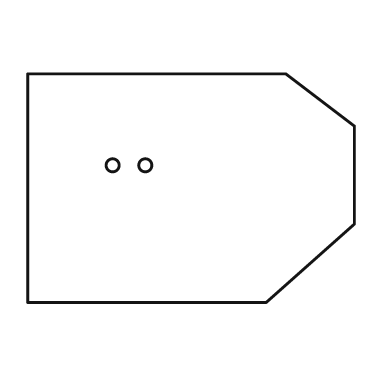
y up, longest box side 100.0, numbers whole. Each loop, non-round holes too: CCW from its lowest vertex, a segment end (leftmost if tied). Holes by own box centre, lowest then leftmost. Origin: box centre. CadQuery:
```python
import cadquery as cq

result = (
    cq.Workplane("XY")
    .moveTo(-50.0, -35.0)
    .lineTo(23.0, -35.0)
    .lineTo(50.0, -11.0)
    .lineTo(50.0, 19.0)
    .lineTo(29.0, 35.0)
    .lineTo(-50.0, 35.0)
    .close()
    .moveTo(-24.0, 7.0)
    .circle(2.0)
    .moveTo(-14.0, 7.0)
    .circle(2.0)
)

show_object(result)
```